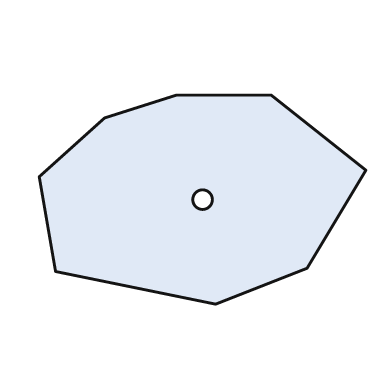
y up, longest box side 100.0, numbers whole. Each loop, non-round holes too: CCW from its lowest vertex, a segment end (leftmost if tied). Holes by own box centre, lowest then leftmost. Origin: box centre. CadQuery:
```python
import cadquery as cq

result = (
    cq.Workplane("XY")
    .moveTo(4.0, -32.0)
    .lineTo(32.0, -21.0)
    .lineTo(50.0, 9.0)
    .lineTo(21.0, 32.0)
    .lineTo(-8.0, 32.0)
    .lineTo(-30.0, 25.0)
    .lineTo(-50.0, 7.0)
    .lineTo(-45.0, -22.0)
    .close()
    .moveTo(0.0, 0.0)
    .circle(3.0)
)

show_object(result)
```